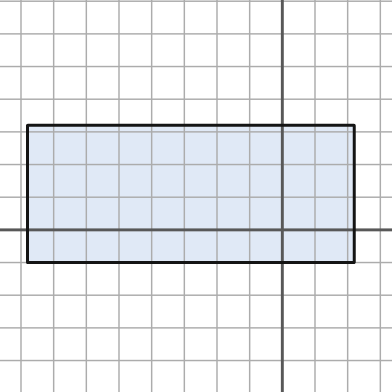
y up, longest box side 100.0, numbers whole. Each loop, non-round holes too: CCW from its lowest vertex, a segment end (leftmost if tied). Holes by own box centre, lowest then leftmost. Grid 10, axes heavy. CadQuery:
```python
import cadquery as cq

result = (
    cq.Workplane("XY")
    .moveTo(-78.0, -10.0)
    .lineTo(22.0, -10.0)
    .lineTo(22.0, 32.0)
    .lineTo(-78.0, 32.0)
    .close()
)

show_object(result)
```